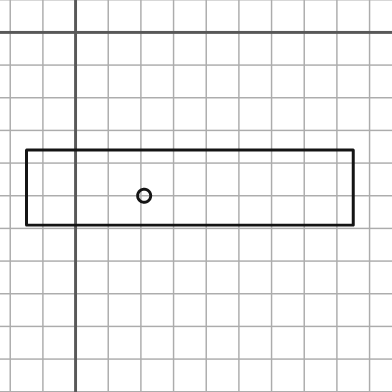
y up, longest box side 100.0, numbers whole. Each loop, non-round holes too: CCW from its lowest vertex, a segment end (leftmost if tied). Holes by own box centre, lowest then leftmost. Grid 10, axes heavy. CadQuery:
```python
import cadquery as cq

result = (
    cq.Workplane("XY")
    .moveTo(-15.0, -59.0)
    .lineTo(85.0, -59.0)
    .lineTo(85.0, -36.0)
    .lineTo(-15.0, -36.0)
    .close()
    .moveTo(21.0, -50.0)
    .circle(2.0)
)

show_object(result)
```